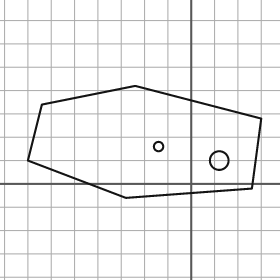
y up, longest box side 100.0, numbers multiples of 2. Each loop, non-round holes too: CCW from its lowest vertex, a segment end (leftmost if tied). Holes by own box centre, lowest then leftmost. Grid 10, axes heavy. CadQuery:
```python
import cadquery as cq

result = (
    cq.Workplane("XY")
    .moveTo(-28.0, -6.0)
    .lineTo(26.0, -2.0)
    .lineTo(30.0, 28.0)
    .lineTo(-24.0, 42.0)
    .lineTo(-64.0, 34.0)
    .lineTo(-70.0, 10.0)
    .close()
    .moveTo(12.0, 10.0)
    .circle(4.0)
    .moveTo(-14.0, 16.0)
    .circle(2.0)
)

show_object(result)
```